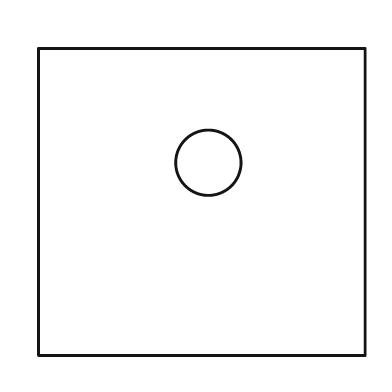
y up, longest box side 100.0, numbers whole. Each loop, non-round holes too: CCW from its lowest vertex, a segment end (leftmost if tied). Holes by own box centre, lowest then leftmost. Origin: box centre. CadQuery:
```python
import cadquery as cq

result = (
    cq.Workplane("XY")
    .moveTo(-50.0, -47.0)
    .lineTo(50.0, -47.0)
    .lineTo(50.0, 47.0)
    .lineTo(-50.0, 47.0)
    .close()
    .moveTo(2.0, 12.0)
    .circle(10.0)
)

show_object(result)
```